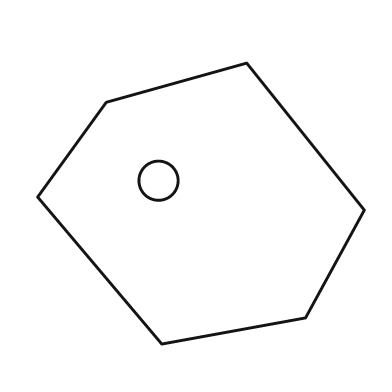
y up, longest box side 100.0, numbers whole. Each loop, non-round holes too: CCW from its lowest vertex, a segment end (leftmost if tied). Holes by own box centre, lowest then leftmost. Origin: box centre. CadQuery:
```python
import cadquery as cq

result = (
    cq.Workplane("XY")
    .moveTo(-12.0, -43.0)
    .lineTo(32.0, -35.0)
    .lineTo(50.0, -2.0)
    .lineTo(14.0, 43.0)
    .lineTo(-29.0, 31.0)
    .lineTo(-50.0, 2.0)
    .close()
    .moveTo(-13.0, 7.0)
    .circle(6.0)
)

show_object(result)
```